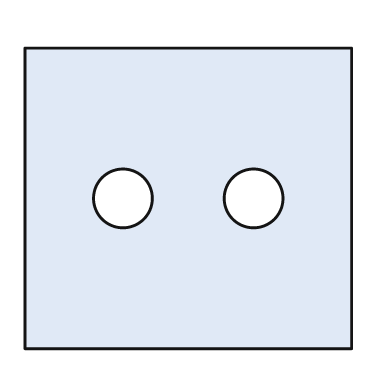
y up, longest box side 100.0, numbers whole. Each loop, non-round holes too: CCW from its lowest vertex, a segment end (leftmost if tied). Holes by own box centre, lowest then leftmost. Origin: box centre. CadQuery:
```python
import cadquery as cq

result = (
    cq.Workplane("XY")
    .moveTo(-50.0, -46.0)
    .lineTo(50.0, -46.0)
    .lineTo(50.0, 46.0)
    .lineTo(-50.0, 46.0)
    .close()
    .moveTo(-20.0, 0.0)
    .circle(9.0)
    .moveTo(20.0, 0.0)
    .circle(9.0)
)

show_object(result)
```